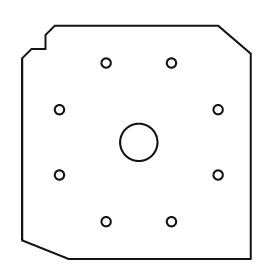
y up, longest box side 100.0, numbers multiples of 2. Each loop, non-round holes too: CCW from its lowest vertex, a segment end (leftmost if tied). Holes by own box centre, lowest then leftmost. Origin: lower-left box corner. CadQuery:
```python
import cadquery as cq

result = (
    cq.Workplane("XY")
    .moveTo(20.0, 0.0)
    .lineTo(98.0, 0.0)
    .lineTo(98.0, 88.0)
    .lineTo(84.0, 100.0)
    .lineTo(14.0, 100.0)
    .lineTo(10.0, 96.0)
    .lineTo(10.0, 90.0)
    .lineTo(4.0, 90.0)
    .lineTo(0.0, 86.0)
    .lineTo(0.0, 8.0)
    .close()
    .moveTo(36.0, 16.0)
    .circle(2.0)
    .moveTo(64.0, 16.0)
    .circle(2.0)
    .moveTo(16.0, 36.0)
    .circle(2.0)
    .moveTo(84.0, 36.0)
    .circle(2.0)
    .moveTo(50.0, 50.0)
    .circle(8.0)
    .moveTo(16.0, 64.0)
    .circle(2.0)
    .moveTo(84.0, 64.0)
    .circle(2.0)
    .moveTo(36.0, 84.0)
    .circle(2.0)
    .moveTo(64.0, 84.0)
    .circle(2.0)
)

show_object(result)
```